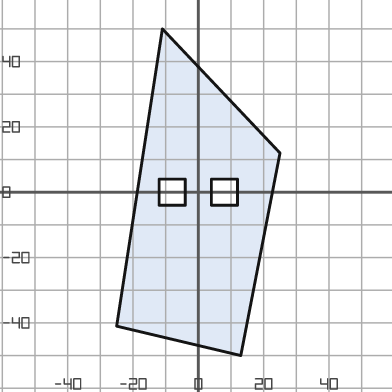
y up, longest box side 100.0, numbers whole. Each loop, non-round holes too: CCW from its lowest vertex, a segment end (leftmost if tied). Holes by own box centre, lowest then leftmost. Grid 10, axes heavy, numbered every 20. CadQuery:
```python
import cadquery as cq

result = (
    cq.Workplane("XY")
    .moveTo(13.0, -50.0)
    .lineTo(25.0, 12.0)
    .lineTo(-11.0, 50.0)
    .lineTo(-25.0, -41.0)
    .close()
    .moveTo(-12.0, -4.0)
    .lineTo(-4.0, -4.0)
    .lineTo(-4.0, 4.0)
    .lineTo(-12.0, 4.0)
    .close()
    .moveTo(4.0, -4.0)
    .lineTo(12.0, -4.0)
    .lineTo(12.0, 4.0)
    .lineTo(4.0, 4.0)
    .close()
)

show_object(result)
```